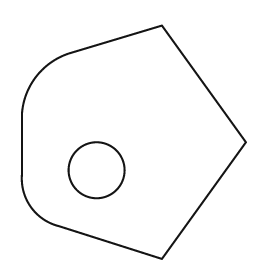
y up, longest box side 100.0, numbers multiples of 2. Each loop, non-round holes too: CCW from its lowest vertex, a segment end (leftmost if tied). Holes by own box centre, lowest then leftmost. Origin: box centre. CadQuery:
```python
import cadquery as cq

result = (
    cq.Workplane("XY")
    .moveTo(12.0, -50.0)
    .lineTo(48.0, 0.0)
    .lineTo(12.0, 50.0)
    .lineTo(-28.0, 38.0)
    .threePointArc((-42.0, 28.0), (-48.0, 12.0))
    .lineTo(-48.0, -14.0)
    .threePointArc((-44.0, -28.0), (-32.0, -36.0))
    .close()
    .moveTo(-16.0, -12.0)
    .circle(12.0)
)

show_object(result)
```